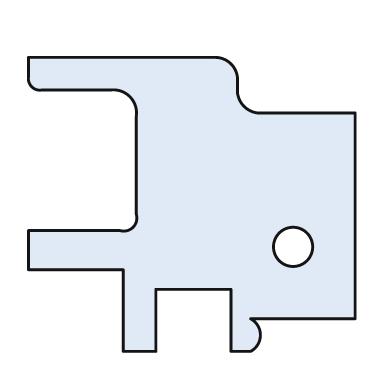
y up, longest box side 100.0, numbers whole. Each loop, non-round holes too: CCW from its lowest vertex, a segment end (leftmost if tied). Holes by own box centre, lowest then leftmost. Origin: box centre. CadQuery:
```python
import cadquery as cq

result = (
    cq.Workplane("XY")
    .moveTo(-21.0, -45.0)
    .lineTo(-11.0, -45.0)
    .lineTo(-11.0, -26.0)
    .lineTo(12.0, -26.0)
    .lineTo(12.0, -45.0)
    .lineTo(18.0, -45.0)
    .threePointArc((21.0, -40.0), (18.0, -35.0))
    .lineTo(50.0, -35.0)
    .lineTo(50.0, 28.0)
    .lineTo(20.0, 28.0)
    .threePointArc((16.0, 30.0), (14.0, 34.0))
    .lineTo(14.0, 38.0)
    .threePointArc((12.0, 43.0), (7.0, 45.0))
    .lineTo(-50.0, 45.0)
    .lineTo(-50.0, 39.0)
    .threePointArc((-49.0, 36.0), (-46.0, 35.0))
    .lineTo(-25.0, 35.0)
    .threePointArc((-19.0, 33.0), (-17.0, 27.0))
    .lineTo(-17.0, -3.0)
    .threePointArc((-18.0, -7.0), (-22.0, -8.0))
    .lineTo(-50.0, -8.0)
    .lineTo(-50.0, -20.0)
    .lineTo(-21.0, -20.0)
    .close()
    .moveTo(31.0, -13.0)
    .circle(6.0)
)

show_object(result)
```